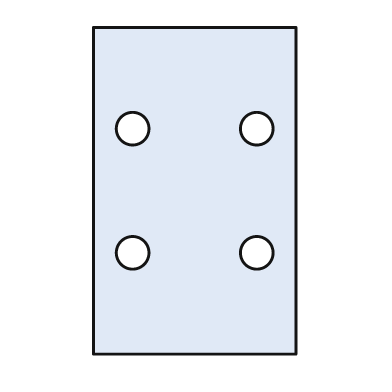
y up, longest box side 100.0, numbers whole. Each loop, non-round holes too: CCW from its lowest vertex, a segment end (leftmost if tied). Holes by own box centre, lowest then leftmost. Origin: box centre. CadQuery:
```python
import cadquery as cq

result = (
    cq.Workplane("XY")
    .moveTo(-31.0, -50.0)
    .lineTo(31.0, -50.0)
    .lineTo(31.0, 50.0)
    .lineTo(-31.0, 50.0)
    .close()
    .moveTo(-19.0, -19.0)
    .circle(5.0)
    .moveTo(19.0, -19.0)
    .circle(5.0)
    .moveTo(-19.0, 19.0)
    .circle(5.0)
    .moveTo(19.0, 19.0)
    .circle(5.0)
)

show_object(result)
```